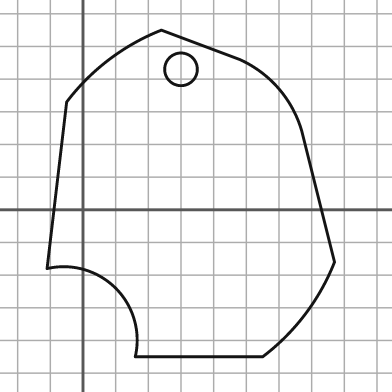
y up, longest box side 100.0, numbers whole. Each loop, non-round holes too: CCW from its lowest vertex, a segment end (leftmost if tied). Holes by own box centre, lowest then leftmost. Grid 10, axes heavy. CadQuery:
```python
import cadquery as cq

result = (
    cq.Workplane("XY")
    .moveTo(16.0, -45.0)
    .lineTo(55.0, -45.0)
    .threePointArc((68.0, -32.0), (77.0, -16.0))
    .lineTo(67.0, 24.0)
    .threePointArc((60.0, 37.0), (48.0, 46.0))
    .lineTo(24.0, 55.0)
    .threePointArc((8.0, 46.0), (-5.0, 33.0))
    .lineTo(-11.0, -18.0)
    .threePointArc((10.0, -24.0), (16.0, -45.0))
    .close()
    .moveTo(30.0, 43.0)
    .circle(5.0)
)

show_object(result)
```